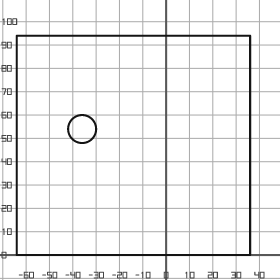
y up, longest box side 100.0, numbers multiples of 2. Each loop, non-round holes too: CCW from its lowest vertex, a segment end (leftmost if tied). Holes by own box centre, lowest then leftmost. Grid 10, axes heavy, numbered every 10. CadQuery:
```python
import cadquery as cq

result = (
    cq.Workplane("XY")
    .moveTo(-64.0, 0.0)
    .lineTo(36.0, 0.0)
    .lineTo(36.0, 94.0)
    .lineTo(-64.0, 94.0)
    .close()
    .moveTo(-36.0, 54.0)
    .circle(6.0)
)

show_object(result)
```